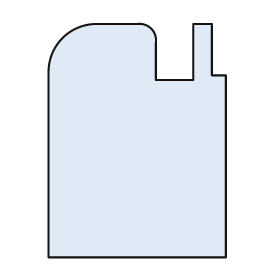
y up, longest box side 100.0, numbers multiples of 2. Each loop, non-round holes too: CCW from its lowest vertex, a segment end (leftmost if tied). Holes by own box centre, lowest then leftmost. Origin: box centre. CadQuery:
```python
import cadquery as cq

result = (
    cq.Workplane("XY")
    .moveTo(-38.0, -50.0)
    .lineTo(38.0, -50.0)
    .lineTo(38.0, 28.0)
    .lineTo(32.0, 28.0)
    .lineTo(32.0, 50.0)
    .lineTo(24.0, 50.0)
    .lineTo(24.0, 26.0)
    .lineTo(8.0, 26.0)
    .lineTo(8.0, 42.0)
    .threePointArc((6.0, 48.0), (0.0, 50.0))
    .lineTo(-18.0, 50.0)
    .threePointArc((-32.0, 44.0), (-38.0, 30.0))
    .close()
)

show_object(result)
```